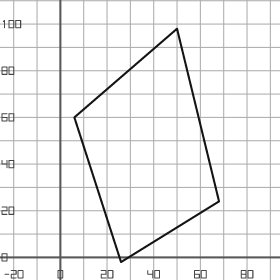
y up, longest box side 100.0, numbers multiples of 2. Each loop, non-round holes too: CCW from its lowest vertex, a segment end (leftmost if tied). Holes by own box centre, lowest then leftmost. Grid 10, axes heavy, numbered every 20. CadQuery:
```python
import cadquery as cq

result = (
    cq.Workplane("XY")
    .moveTo(26.0, -2.0)
    .lineTo(68.0, 24.0)
    .lineTo(50.0, 98.0)
    .lineTo(6.0, 60.0)
    .close()
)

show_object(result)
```